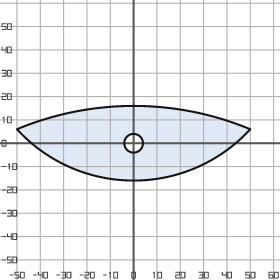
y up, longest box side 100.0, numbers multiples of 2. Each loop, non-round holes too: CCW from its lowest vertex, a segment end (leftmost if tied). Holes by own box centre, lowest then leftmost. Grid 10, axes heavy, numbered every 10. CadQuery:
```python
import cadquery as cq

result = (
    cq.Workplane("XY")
    .moveTo(-50.0, 6.0)
    .threePointArc((0.0, -16.0), (50.0, 6.0))
    .threePointArc((0.0, 16.0), (-50.0, 6.0))
    .close()
    .moveTo(0.0, 0.0)
    .circle(4.0)
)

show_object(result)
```